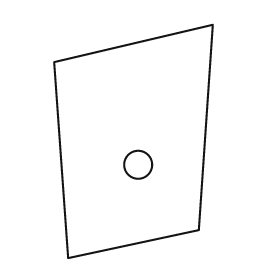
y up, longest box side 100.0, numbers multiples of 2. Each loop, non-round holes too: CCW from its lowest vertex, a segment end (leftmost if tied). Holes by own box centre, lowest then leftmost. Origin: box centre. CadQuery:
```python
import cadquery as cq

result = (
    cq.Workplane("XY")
    .moveTo(-28.0, -50.0)
    .lineTo(28.0, -38.0)
    .lineTo(34.0, 50.0)
    .lineTo(-34.0, 34.0)
    .close()
    .moveTo(2.0, -10.0)
    .circle(6.0)
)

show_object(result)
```